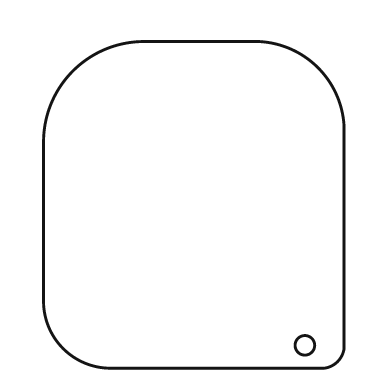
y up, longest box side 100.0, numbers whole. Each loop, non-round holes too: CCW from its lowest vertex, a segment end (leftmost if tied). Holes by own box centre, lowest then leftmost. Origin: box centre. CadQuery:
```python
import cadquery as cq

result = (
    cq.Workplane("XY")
    .moveTo(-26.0, -50.0)
    .lineTo(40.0, -50.0)
    .threePointArc((44.0, -48.0), (46.0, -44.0))
    .lineTo(46.0, 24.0)
    .threePointArc((38.0, 42.0), (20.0, 50.0))
    .lineTo(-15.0, 50.0)
    .threePointArc((-37.0, 41.0), (-46.0, 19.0))
    .lineTo(-46.0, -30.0)
    .threePointArc((-40.0, -44.0), (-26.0, -50.0))
    .close()
    .moveTo(34.0, -43.0)
    .circle(3.0)
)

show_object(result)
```